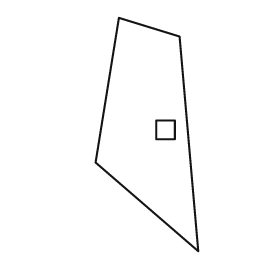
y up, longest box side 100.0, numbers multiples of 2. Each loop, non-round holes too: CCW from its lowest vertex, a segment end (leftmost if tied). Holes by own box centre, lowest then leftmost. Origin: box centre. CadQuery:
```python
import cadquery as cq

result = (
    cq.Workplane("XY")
    .moveTo(22.0, -50.0)
    .lineTo(14.0, 42.0)
    .lineTo(-12.0, 50.0)
    .lineTo(-22.0, -12.0)
    .close()
    .moveTo(4.0, -2.0)
    .lineTo(12.0, -2.0)
    .lineTo(12.0, 6.0)
    .lineTo(4.0, 6.0)
    .close()
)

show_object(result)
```